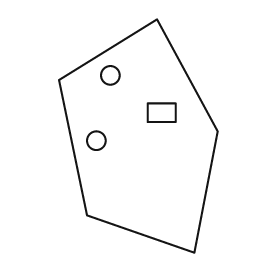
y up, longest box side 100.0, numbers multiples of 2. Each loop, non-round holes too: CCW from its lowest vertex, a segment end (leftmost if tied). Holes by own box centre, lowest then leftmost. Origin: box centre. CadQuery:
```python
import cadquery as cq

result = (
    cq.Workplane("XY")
    .moveTo(24.0, -50.0)
    .lineTo(34.0, 2.0)
    .lineTo(8.0, 50.0)
    .lineTo(-34.0, 24.0)
    .lineTo(-22.0, -34.0)
    .close()
    .moveTo(-18.0, -2.0)
    .circle(4.0)
    .moveTo(4.0, 6.0)
    .lineTo(16.0, 6.0)
    .lineTo(16.0, 14.0)
    .lineTo(4.0, 14.0)
    .close()
    .moveTo(-12.0, 26.0)
    .circle(4.0)
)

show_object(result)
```